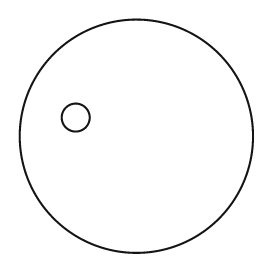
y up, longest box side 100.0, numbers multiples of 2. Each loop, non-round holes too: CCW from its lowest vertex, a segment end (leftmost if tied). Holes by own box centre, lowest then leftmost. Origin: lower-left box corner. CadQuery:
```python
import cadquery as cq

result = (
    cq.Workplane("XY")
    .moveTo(50.0, 50.0)
    .circle(50.0)
    .moveTo(24.0, 58.0)
    .circle(6.0)
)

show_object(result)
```